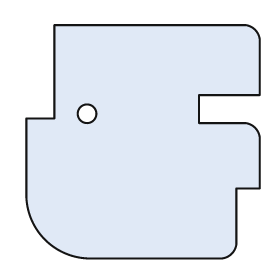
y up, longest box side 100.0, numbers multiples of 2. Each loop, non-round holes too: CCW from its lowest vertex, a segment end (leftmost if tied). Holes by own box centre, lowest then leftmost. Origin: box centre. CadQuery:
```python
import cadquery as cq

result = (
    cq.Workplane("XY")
    .moveTo(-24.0, -50.0)
    .lineTo(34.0, -50.0)
    .threePointArc((38.0, -48.0), (40.0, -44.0))
    .lineTo(40.0, -20.0)
    .lineTo(50.0, -20.0)
    .lineTo(50.0, 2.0)
    .threePointArc((48.0, 6.0), (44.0, 8.0))
    .lineTo(24.0, 8.0)
    .lineTo(24.0, 20.0)
    .lineTo(50.0, 20.0)
    .lineTo(50.0, 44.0)
    .threePointArc((48.0, 48.0), (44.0, 50.0))
    .lineTo(-38.0, 50.0)
    .lineTo(-38.0, 10.0)
    .lineTo(-50.0, 10.0)
    .lineTo(-50.0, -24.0)
    .threePointArc((-42.0, -42.0), (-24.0, -50.0))
    .close()
    .moveTo(-24.0, 12.0)
    .circle(4.0)
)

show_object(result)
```